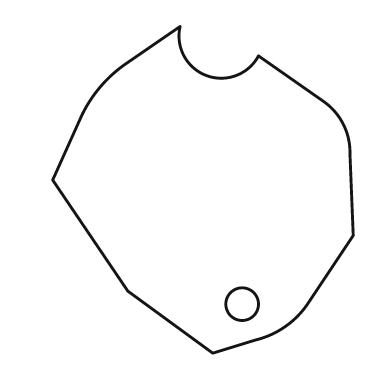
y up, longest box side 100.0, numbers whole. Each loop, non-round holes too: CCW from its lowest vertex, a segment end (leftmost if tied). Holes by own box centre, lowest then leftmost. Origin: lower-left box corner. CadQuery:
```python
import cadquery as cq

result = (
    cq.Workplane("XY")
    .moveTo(49.0, 0.0)
    .lineTo(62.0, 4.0)
    .threePointArc((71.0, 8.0), (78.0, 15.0))
    .lineTo(92.0, 36.0)
    .lineTo(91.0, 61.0)
    .threePointArc((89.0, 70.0), (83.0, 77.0))
    .lineTo(63.0, 91.0)
    .threePointArc((47.0, 85.0), (39.0, 100.0))
    .lineTo(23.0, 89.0)
    .threePointArc((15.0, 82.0), (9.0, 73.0))
    .lineTo(0.0, 53.0)
    .lineTo(23.0, 19.0)
    .close()
    .moveTo(58.0, 15.0)
    .circle(5.0)
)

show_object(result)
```